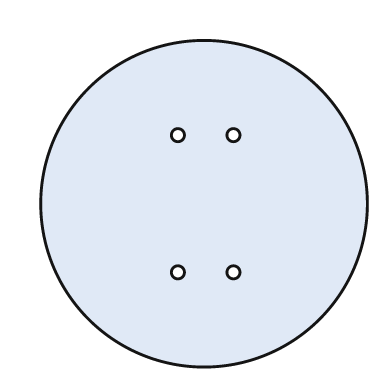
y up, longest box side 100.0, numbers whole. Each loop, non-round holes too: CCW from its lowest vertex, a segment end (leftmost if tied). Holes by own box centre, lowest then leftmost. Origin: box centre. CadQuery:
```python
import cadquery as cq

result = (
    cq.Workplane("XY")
    .moveTo(0.0, 0.0)
    .circle(50.0)
    .moveTo(-8.0, -21.0)
    .circle(2.0)
    .moveTo(9.0, -21.0)
    .circle(2.0)
    .moveTo(-8.0, 21.0)
    .circle(2.0)
    .moveTo(9.0, 21.0)
    .circle(2.0)
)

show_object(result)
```